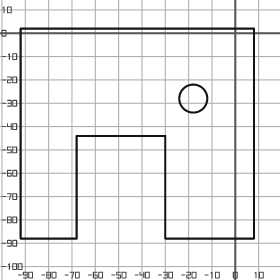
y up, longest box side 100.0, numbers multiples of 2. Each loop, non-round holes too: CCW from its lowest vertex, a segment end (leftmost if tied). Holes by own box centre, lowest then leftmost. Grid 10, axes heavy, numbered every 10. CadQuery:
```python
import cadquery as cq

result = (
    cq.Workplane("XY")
    .moveTo(-92.0, -88.0)
    .lineTo(-68.0, -88.0)
    .lineTo(-68.0, -44.0)
    .lineTo(-30.0, -44.0)
    .lineTo(-30.0, -88.0)
    .lineTo(8.0, -88.0)
    .lineTo(8.0, 2.0)
    .lineTo(-92.0, 2.0)
    .close()
    .moveTo(-18.0, -28.0)
    .circle(6.0)
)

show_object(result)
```